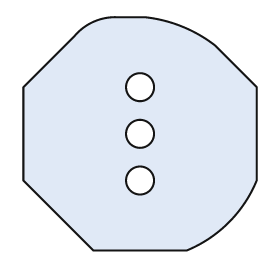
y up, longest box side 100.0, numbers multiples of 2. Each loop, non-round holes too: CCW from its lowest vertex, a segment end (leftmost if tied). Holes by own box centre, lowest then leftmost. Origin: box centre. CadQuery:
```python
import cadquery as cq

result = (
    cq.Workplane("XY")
    .moveTo(-20.0, -50.0)
    .lineTo(20.0, -50.0)
    .threePointArc((38.0, -38.0), (50.0, -20.0))
    .lineTo(50.0, 20.0)
    .lineTo(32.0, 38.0)
    .threePointArc((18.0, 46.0), (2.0, 50.0))
    .lineTo(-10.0, 50.0)
    .threePointArc((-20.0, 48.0), (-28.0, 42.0))
    .lineTo(-50.0, 20.0)
    .lineTo(-50.0, -20.0)
    .close()
    .moveTo(0.0, -20.0)
    .circle(6.0)
    .moveTo(0.0, 0.0)
    .circle(6.0)
    .moveTo(0.0, 20.0)
    .circle(6.0)
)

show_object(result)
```